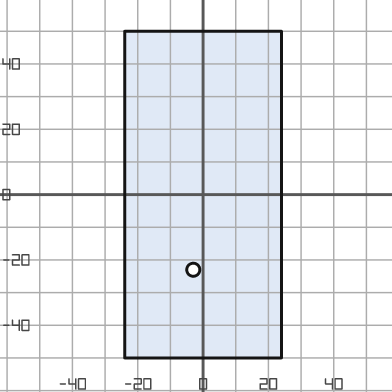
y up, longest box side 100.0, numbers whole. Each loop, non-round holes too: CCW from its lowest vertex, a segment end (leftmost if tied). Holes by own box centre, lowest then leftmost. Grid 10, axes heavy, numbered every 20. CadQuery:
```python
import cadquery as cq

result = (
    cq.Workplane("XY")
    .moveTo(-24.0, -50.0)
    .lineTo(24.0, -50.0)
    .lineTo(24.0, 50.0)
    .lineTo(-24.0, 50.0)
    .close()
    .moveTo(-3.0, -23.0)
    .circle(2.0)
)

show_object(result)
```